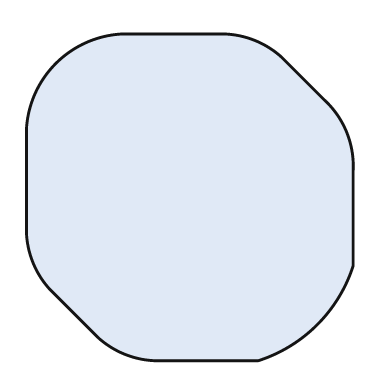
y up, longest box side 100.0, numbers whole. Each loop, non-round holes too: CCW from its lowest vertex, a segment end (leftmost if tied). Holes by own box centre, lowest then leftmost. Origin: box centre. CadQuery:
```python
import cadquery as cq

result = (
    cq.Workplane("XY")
    .moveTo(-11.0, -50.0)
    .lineTo(21.0, -50.0)
    .threePointArc((39.0, -39.0), (50.0, -21.0))
    .lineTo(50.0, 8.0)
    .threePointArc((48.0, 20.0), (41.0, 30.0))
    .lineTo(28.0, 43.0)
    .threePointArc((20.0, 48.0), (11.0, 50.0))
    .lineTo(-21.0, 50.0)
    .threePointArc((-41.0, 41.0), (-50.0, 21.0))
    .lineTo(-50.0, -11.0)
    .threePointArc((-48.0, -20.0), (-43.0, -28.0))
    .lineTo(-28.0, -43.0)
    .threePointArc((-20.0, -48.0), (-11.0, -50.0))
    .close()
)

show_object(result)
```